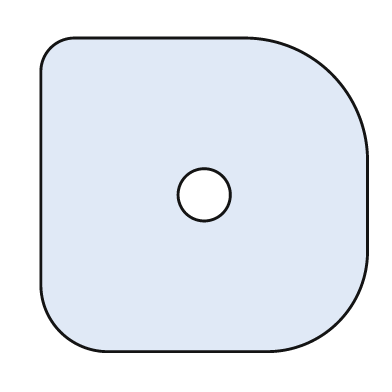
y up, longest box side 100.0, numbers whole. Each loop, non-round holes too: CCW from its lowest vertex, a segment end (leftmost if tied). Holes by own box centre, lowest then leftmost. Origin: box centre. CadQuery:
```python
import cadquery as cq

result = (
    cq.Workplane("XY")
    .moveTo(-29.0, -48.0)
    .lineTo(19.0, -48.0)
    .threePointArc((41.0, -39.0), (50.0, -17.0))
    .lineTo(50.0, 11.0)
    .threePointArc((39.0, 37.0), (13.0, 48.0))
    .lineTo(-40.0, 48.0)
    .threePointArc((-47.0, 45.0), (-50.0, 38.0))
    .lineTo(-50.0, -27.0)
    .threePointArc((-44.0, -42.0), (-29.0, -48.0))
    .close()
    .moveTo(0.0, 0.0)
    .circle(8.0)
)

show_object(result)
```